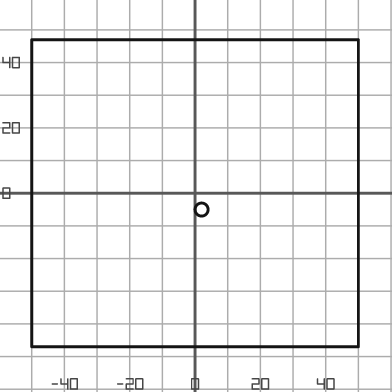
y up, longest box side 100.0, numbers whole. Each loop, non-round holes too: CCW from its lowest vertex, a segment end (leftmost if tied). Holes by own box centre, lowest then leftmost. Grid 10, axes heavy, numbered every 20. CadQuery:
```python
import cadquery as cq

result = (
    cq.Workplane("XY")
    .moveTo(-50.0, -47.0)
    .lineTo(50.0, -47.0)
    .lineTo(50.0, 47.0)
    .lineTo(-50.0, 47.0)
    .close()
    .moveTo(2.0, -5.0)
    .circle(2.0)
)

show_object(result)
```